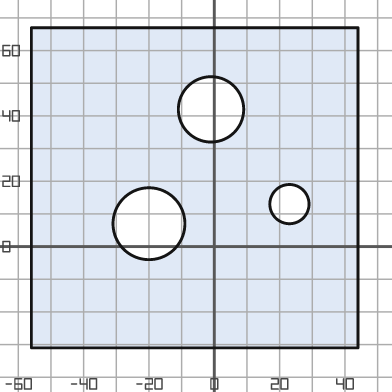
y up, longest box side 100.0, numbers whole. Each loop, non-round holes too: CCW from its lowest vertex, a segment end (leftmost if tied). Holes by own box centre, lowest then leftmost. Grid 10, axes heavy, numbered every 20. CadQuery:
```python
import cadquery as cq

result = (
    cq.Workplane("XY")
    .moveTo(-56.0, -31.0)
    .lineTo(44.0, -31.0)
    .lineTo(44.0, 67.0)
    .lineTo(-56.0, 67.0)
    .close()
    .moveTo(-20.0, 7.0)
    .circle(11.0)
    .moveTo(23.0, 13.0)
    .circle(6.0)
    .moveTo(-1.0, 42.0)
    .circle(10.0)
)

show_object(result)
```